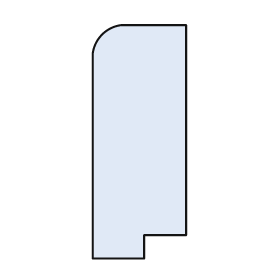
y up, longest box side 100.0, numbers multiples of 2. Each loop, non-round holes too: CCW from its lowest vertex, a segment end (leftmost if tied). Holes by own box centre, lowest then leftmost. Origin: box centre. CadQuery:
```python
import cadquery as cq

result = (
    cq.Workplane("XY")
    .moveTo(-20.0, -50.0)
    .lineTo(2.0, -50.0)
    .lineTo(2.0, -40.0)
    .lineTo(20.0, -40.0)
    .lineTo(20.0, 50.0)
    .lineTo(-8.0, 50.0)
    .threePointArc((-16.0, 46.0), (-20.0, 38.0))
    .close()
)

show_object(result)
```